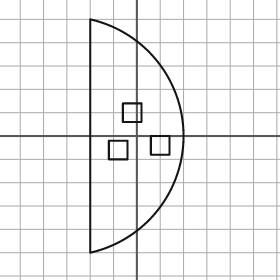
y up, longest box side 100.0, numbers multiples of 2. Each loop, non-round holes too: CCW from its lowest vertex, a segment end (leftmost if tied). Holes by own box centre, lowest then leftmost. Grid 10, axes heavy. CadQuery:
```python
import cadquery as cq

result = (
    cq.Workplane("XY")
    .moveTo(-20.0, -50.0)
    .threePointArc((20.0, 0.0), (-20.0, 50.0))
    .close()
    .moveTo(-12.0, -10.0)
    .lineTo(-4.0, -10.0)
    .lineTo(-4.0, -2.0)
    .lineTo(-12.0, -2.0)
    .close()
    .moveTo(6.0, -8.0)
    .lineTo(14.0, -8.0)
    .lineTo(14.0, 0.0)
    .lineTo(6.0, 0.0)
    .close()
    .moveTo(-6.0, 6.0)
    .lineTo(2.0, 6.0)
    .lineTo(2.0, 14.0)
    .lineTo(-6.0, 14.0)
    .close()
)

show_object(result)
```